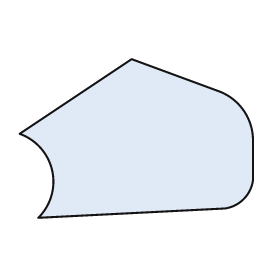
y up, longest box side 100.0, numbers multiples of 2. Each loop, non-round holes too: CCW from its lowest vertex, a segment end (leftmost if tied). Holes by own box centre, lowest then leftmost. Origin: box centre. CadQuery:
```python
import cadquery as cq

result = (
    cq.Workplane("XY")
    .moveTo(-42.0, -34.0)
    .lineTo(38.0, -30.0)
    .threePointArc((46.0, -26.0), (50.0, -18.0))
    .lineTo(50.0, 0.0)
    .threePointArc((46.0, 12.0), (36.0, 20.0))
    .lineTo(-2.0, 34.0)
    .lineTo(-50.0, 2.0)
    .threePointArc((-36.0, -14.0), (-42.0, -34.0))
    .close()
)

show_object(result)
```